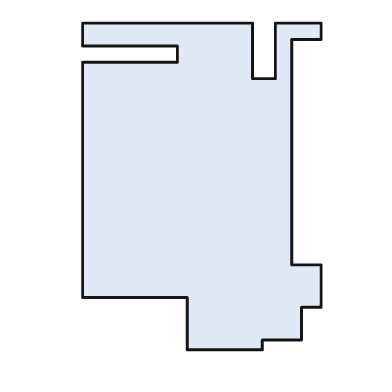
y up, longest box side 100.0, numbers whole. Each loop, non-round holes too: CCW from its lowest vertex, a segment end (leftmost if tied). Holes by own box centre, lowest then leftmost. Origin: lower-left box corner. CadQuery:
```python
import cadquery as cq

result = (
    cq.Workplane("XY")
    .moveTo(32.0, 0.0)
    .lineTo(55.0, 0.0)
    .lineTo(55.0, 3.0)
    .lineTo(67.0, 3.0)
    .lineTo(67.0, 13.0)
    .lineTo(73.0, 13.0)
    .lineTo(73.0, 26.0)
    .lineTo(64.0, 26.0)
    .lineTo(64.0, 95.0)
    .lineTo(73.0, 95.0)
    .lineTo(73.0, 100.0)
    .lineTo(59.0, 100.0)
    .lineTo(59.0, 83.0)
    .lineTo(52.0, 83.0)
    .lineTo(52.0, 100.0)
    .lineTo(0.0, 100.0)
    .lineTo(0.0, 93.0)
    .lineTo(29.0, 93.0)
    .lineTo(29.0, 88.0)
    .lineTo(0.0, 88.0)
    .lineTo(0.0, 16.0)
    .lineTo(32.0, 16.0)
    .close()
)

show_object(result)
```